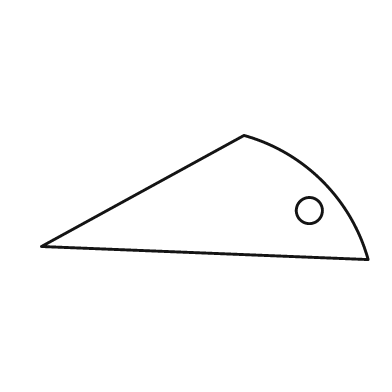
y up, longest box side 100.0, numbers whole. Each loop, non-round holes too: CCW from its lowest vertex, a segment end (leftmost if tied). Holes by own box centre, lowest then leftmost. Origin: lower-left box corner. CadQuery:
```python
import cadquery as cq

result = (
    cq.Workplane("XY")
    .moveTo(100.0, 0.0)
    .threePointArc((86.0, 24.0), (62.0, 38.0))
    .lineTo(0.0, 4.0)
    .close()
    .moveTo(82.0, 15.0)
    .circle(4.0)
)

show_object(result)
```